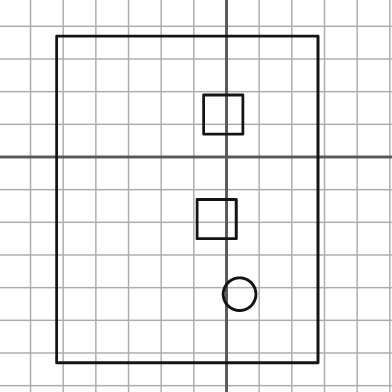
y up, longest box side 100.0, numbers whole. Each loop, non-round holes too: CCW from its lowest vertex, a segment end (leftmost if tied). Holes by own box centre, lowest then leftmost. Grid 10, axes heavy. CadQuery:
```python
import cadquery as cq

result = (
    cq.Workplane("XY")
    .moveTo(-52.0, -63.0)
    .lineTo(28.0, -63.0)
    .lineTo(28.0, 37.0)
    .lineTo(-52.0, 37.0)
    .close()
    .moveTo(4.0, -42.0)
    .circle(5.0)
    .moveTo(-9.0, -25.0)
    .lineTo(3.0, -25.0)
    .lineTo(3.0, -13.0)
    .lineTo(-9.0, -13.0)
    .close()
    .moveTo(-7.0, 7.0)
    .lineTo(5.0, 7.0)
    .lineTo(5.0, 19.0)
    .lineTo(-7.0, 19.0)
    .close()
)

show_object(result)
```